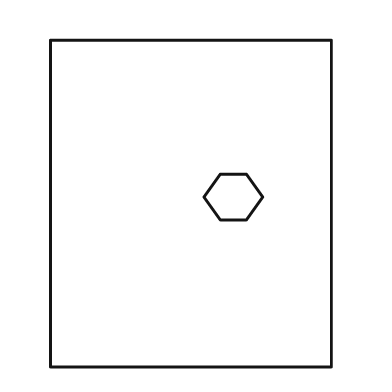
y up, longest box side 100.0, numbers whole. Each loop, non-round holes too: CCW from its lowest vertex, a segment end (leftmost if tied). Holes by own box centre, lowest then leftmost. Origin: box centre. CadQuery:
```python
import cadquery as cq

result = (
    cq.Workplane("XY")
    .moveTo(-43.0, -50.0)
    .lineTo(43.0, -50.0)
    .lineTo(43.0, 50.0)
    .lineTo(-43.0, 50.0)
    .close()
    .moveTo(9.0, -5.0)
    .lineTo(17.0, -5.0)
    .lineTo(22.0, 2.0)
    .lineTo(17.0, 9.0)
    .lineTo(9.0, 9.0)
    .lineTo(4.0, 2.0)
    .close()
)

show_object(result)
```